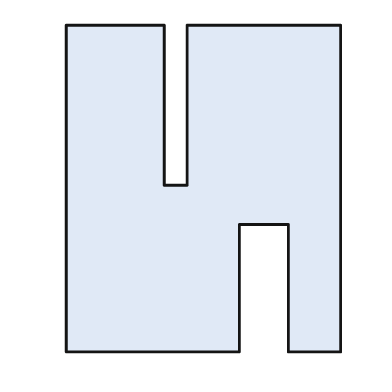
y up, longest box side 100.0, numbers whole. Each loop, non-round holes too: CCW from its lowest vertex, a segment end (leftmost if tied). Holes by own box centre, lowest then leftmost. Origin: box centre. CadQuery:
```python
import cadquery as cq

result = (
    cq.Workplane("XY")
    .moveTo(-42.0, -50.0)
    .lineTo(11.0, -50.0)
    .lineTo(11.0, -11.0)
    .lineTo(26.0, -11.0)
    .lineTo(26.0, -50.0)
    .lineTo(42.0, -50.0)
    .lineTo(42.0, 50.0)
    .lineTo(-5.0, 50.0)
    .lineTo(-5.0, 1.0)
    .lineTo(-12.0, 1.0)
    .lineTo(-12.0, 50.0)
    .lineTo(-42.0, 50.0)
    .close()
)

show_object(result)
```